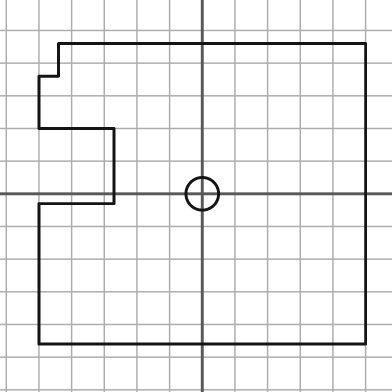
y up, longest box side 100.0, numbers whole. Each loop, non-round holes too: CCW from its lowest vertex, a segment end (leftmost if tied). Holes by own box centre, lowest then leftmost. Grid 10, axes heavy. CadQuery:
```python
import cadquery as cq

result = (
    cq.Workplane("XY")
    .moveTo(-50.0, -46.0)
    .lineTo(50.0, -46.0)
    .lineTo(50.0, 46.0)
    .lineTo(-44.0, 46.0)
    .lineTo(-44.0, 36.0)
    .lineTo(-50.0, 36.0)
    .lineTo(-50.0, 20.0)
    .lineTo(-27.0, 20.0)
    .lineTo(-27.0, -3.0)
    .lineTo(-50.0, -3.0)
    .close()
    .moveTo(0.0, 0.0)
    .circle(5.0)
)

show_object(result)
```